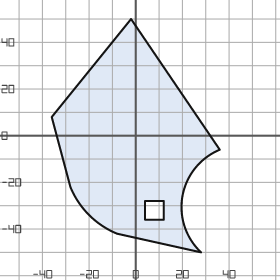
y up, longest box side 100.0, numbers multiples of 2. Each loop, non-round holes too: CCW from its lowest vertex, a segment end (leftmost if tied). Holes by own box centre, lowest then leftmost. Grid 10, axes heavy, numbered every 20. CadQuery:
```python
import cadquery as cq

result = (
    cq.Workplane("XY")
    .moveTo(28.0, -50.0)
    .threePointArc((20.0, -26.0), (36.0, -6.0))
    .lineTo(-2.0, 50.0)
    .lineTo(-36.0, 8.0)
    .lineTo(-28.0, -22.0)
    .threePointArc((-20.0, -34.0), (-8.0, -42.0))
    .close()
    .moveTo(4.0, -36.0)
    .lineTo(12.0, -36.0)
    .lineTo(12.0, -28.0)
    .lineTo(4.0, -28.0)
    .close()
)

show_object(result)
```